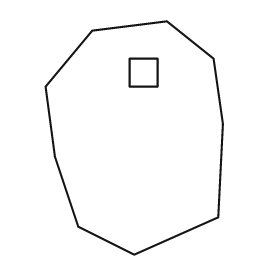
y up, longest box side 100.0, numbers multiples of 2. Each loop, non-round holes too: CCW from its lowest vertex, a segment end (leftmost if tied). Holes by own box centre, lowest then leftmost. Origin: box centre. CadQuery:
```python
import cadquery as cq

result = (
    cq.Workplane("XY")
    .moveTo(0.0, -50.0)
    .lineTo(36.0, -34.0)
    .lineTo(38.0, 6.0)
    .lineTo(34.0, 34.0)
    .lineTo(14.0, 50.0)
    .lineTo(-18.0, 46.0)
    .lineTo(-38.0, 22.0)
    .lineTo(-34.0, -8.0)
    .lineTo(-24.0, -38.0)
    .close()
    .moveTo(-2.0, 22.0)
    .lineTo(10.0, 22.0)
    .lineTo(10.0, 34.0)
    .lineTo(-2.0, 34.0)
    .close()
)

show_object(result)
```